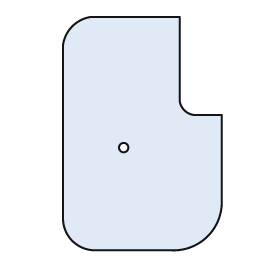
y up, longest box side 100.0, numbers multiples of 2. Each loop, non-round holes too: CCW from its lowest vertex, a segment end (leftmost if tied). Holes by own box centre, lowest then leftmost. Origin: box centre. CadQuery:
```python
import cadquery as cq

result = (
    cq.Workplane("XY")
    .moveTo(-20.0, -50.0)
    .lineTo(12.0, -50.0)
    .threePointArc((28.0, -44.0), (34.0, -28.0))
    .lineTo(34.0, 8.0)
    .lineTo(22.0, 8.0)
    .threePointArc((18.0, 10.0), (16.0, 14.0))
    .lineTo(16.0, 50.0)
    .lineTo(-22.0, 50.0)
    .threePointArc((-30.0, 46.0), (-34.0, 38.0))
    .lineTo(-34.0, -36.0)
    .threePointArc((-30.0, -46.0), (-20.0, -50.0))
    .close()
    .moveTo(-8.0, -6.0)
    .circle(2.0)
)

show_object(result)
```